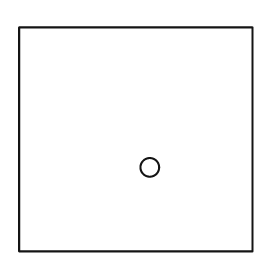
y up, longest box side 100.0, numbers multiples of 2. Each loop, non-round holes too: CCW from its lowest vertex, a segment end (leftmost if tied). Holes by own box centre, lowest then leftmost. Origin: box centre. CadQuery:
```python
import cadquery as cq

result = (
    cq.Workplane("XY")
    .moveTo(-50.0, -48.0)
    .lineTo(50.0, -48.0)
    .lineTo(50.0, 48.0)
    .lineTo(-50.0, 48.0)
    .close()
    .moveTo(6.0, -12.0)
    .circle(4.0)
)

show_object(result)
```